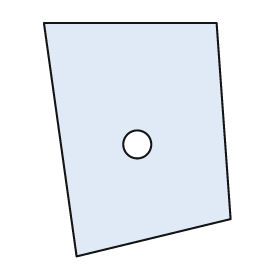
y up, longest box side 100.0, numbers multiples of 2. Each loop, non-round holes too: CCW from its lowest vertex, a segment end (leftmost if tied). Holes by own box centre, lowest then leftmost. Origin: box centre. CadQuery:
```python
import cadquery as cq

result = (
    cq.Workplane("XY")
    .moveTo(-26.0, -50.0)
    .lineTo(40.0, -34.0)
    .lineTo(34.0, 50.0)
    .lineTo(-40.0, 50.0)
    .close()
    .moveTo(0.0, -2.0)
    .circle(6.0)
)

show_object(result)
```